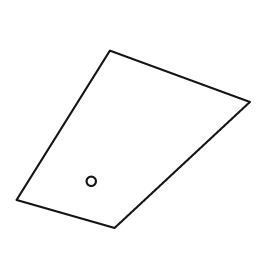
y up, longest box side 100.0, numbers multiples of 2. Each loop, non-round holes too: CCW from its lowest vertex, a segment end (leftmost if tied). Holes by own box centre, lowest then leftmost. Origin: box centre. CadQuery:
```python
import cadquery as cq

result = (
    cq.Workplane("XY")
    .moveTo(-8.0, -38.0)
    .lineTo(50.0, 16.0)
    .lineTo(-10.0, 38.0)
    .lineTo(-50.0, -26.0)
    .close()
    .moveTo(-18.0, -18.0)
    .circle(2.0)
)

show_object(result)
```